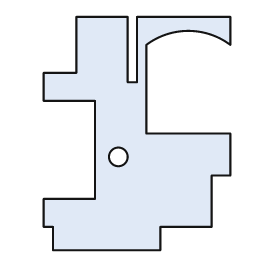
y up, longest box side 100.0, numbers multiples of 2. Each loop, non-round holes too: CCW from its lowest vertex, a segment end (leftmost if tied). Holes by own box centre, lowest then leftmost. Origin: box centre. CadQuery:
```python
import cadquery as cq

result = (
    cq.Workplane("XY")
    .moveTo(-36.0, -50.0)
    .lineTo(10.0, -50.0)
    .lineTo(10.0, -40.0)
    .lineTo(32.0, -40.0)
    .lineTo(32.0, -18.0)
    .lineTo(40.0, -18.0)
    .lineTo(40.0, 0.0)
    .lineTo(4.0, 0.0)
    .lineTo(4.0, 38.0)
    .threePointArc((22.0, 44.0), (40.0, 38.0))
    .lineTo(40.0, 50.0)
    .lineTo(0.0, 50.0)
    .lineTo(0.0, 22.0)
    .lineTo(-4.0, 22.0)
    .lineTo(-4.0, 50.0)
    .lineTo(-26.0, 50.0)
    .lineTo(-26.0, 26.0)
    .lineTo(-40.0, 26.0)
    .lineTo(-40.0, 14.0)
    .lineTo(-18.0, 14.0)
    .lineTo(-18.0, -28.0)
    .lineTo(-40.0, -28.0)
    .lineTo(-40.0, -40.0)
    .lineTo(-36.0, -40.0)
    .close()
    .moveTo(-8.0, -10.0)
    .circle(4.0)
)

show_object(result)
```